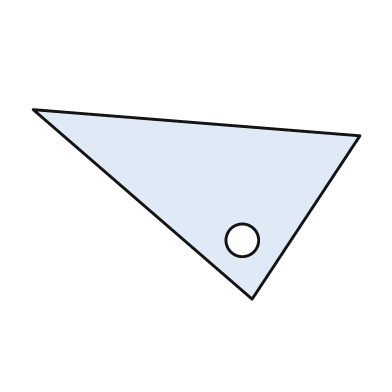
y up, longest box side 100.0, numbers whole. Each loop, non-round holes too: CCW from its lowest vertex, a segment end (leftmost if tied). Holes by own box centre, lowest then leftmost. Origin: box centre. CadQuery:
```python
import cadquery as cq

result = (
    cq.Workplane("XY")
    .moveTo(17.0, -29.0)
    .lineTo(50.0, 21.0)
    .lineTo(-50.0, 29.0)
    .close()
    .moveTo(14.0, -11.0)
    .circle(5.0)
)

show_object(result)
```